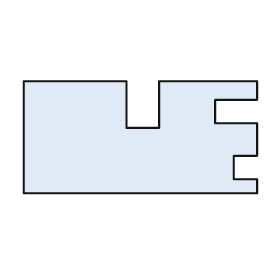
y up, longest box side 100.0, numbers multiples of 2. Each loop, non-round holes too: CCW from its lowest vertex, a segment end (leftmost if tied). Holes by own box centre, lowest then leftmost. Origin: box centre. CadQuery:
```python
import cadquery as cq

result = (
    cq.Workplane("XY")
    .moveTo(-50.0, -24.0)
    .lineTo(50.0, -24.0)
    .lineTo(50.0, -18.0)
    .lineTo(40.0, -18.0)
    .lineTo(40.0, -8.0)
    .lineTo(50.0, -8.0)
    .lineTo(50.0, 6.0)
    .lineTo(32.0, 6.0)
    .lineTo(32.0, 16.0)
    .lineTo(50.0, 16.0)
    .lineTo(50.0, 24.0)
    .lineTo(8.0, 24.0)
    .lineTo(8.0, 4.0)
    .lineTo(-6.0, 4.0)
    .lineTo(-6.0, 24.0)
    .lineTo(-50.0, 24.0)
    .close()
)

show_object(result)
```